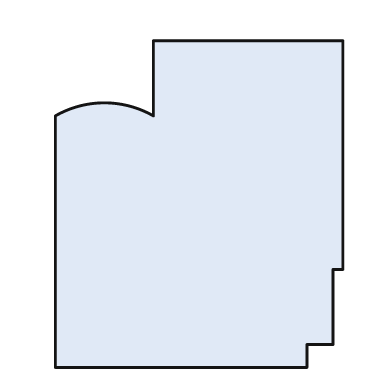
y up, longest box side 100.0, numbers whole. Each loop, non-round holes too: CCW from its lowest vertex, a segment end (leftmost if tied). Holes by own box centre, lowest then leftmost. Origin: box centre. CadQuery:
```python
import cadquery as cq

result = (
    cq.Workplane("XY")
    .moveTo(-44.0, -50.0)
    .lineTo(33.0, -50.0)
    .lineTo(33.0, -43.0)
    .lineTo(41.0, -43.0)
    .lineTo(41.0, -20.0)
    .lineTo(44.0, -20.0)
    .lineTo(44.0, 50.0)
    .lineTo(-14.0, 50.0)
    .lineTo(-14.0, 27.0)
    .threePointArc((-29.0, 31.0), (-44.0, 27.0))
    .close()
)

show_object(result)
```